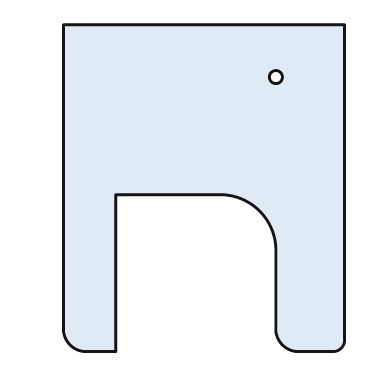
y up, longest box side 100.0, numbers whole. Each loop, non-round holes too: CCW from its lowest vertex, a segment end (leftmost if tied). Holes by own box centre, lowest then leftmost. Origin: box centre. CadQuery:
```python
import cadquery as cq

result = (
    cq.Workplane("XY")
    .moveTo(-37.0, -50.0)
    .lineTo(-27.0, -50.0)
    .lineTo(-27.0, -2.0)
    .lineTo(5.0, -2.0)
    .threePointArc((17.0, -7.0), (22.0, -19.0))
    .lineTo(22.0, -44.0)
    .threePointArc((24.0, -48.0), (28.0, -50.0))
    .lineTo(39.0, -50.0)
    .threePointArc((42.0, -49.0), (43.0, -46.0))
    .lineTo(43.0, 50.0)
    .lineTo(-43.0, 50.0)
    .lineTo(-43.0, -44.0)
    .threePointArc((-41.0, -48.0), (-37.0, -50.0))
    .close()
    .moveTo(22.0, 34.0)
    .circle(2.0)
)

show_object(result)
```